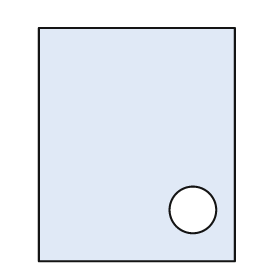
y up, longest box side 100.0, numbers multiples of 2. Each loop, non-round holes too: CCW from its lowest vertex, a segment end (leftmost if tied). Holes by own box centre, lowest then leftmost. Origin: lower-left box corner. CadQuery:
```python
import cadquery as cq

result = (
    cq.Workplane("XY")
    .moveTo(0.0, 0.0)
    .lineTo(84.0, 0.0)
    .lineTo(84.0, 100.0)
    .lineTo(0.0, 100.0)
    .close()
    .moveTo(66.0, 22.0)
    .circle(10.0)
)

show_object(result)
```